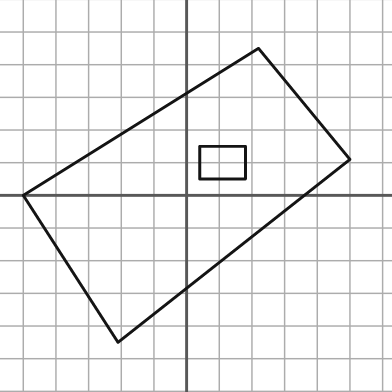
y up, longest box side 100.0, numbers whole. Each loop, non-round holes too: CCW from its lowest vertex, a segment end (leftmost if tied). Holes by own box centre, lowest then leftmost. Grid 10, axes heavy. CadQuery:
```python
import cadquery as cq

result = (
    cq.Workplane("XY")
    .moveTo(-21.0, -45.0)
    .lineTo(50.0, 11.0)
    .lineTo(22.0, 45.0)
    .lineTo(-50.0, 0.0)
    .close()
    .moveTo(4.0, 5.0)
    .lineTo(18.0, 5.0)
    .lineTo(18.0, 15.0)
    .lineTo(4.0, 15.0)
    .close()
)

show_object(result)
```